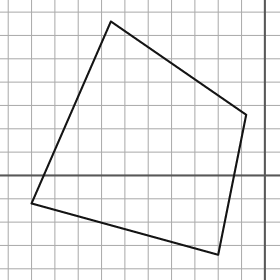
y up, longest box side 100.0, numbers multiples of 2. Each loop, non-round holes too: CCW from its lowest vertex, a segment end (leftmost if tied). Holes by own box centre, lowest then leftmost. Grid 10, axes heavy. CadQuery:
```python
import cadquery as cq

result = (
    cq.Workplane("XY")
    .moveTo(-20.0, -34.0)
    .lineTo(-8.0, 26.0)
    .lineTo(-66.0, 66.0)
    .lineTo(-100.0, -12.0)
    .close()
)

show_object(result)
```